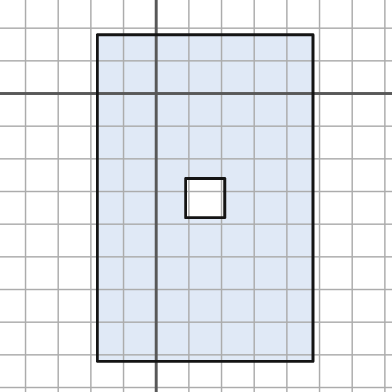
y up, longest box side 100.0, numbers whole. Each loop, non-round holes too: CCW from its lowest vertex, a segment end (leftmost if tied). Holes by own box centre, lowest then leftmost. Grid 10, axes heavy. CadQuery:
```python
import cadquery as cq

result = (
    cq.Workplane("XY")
    .moveTo(-18.0, -82.0)
    .lineTo(48.0, -82.0)
    .lineTo(48.0, 18.0)
    .lineTo(-18.0, 18.0)
    .close()
    .moveTo(9.0, -38.0)
    .lineTo(21.0, -38.0)
    .lineTo(21.0, -26.0)
    .lineTo(9.0, -26.0)
    .close()
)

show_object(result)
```